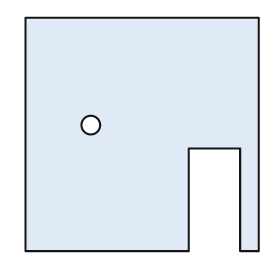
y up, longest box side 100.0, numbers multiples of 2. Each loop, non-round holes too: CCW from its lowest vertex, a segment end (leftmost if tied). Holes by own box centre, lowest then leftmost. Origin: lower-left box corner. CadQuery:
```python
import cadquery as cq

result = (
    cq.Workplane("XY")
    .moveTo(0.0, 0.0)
    .lineTo(70.0, 0.0)
    .lineTo(70.0, 44.0)
    .lineTo(92.0, 44.0)
    .lineTo(92.0, 0.0)
    .lineTo(100.0, 0.0)
    .lineTo(100.0, 100.0)
    .lineTo(0.0, 100.0)
    .close()
    .moveTo(28.0, 54.0)
    .circle(4.0)
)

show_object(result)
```